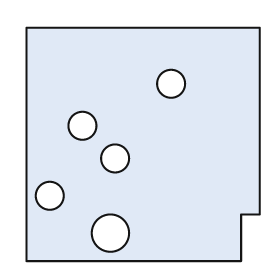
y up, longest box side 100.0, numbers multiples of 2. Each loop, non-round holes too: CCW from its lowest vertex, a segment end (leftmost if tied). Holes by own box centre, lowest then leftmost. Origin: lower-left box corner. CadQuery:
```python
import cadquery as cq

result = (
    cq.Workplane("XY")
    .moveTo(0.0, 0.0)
    .lineTo(92.0, 0.0)
    .lineTo(92.0, 20.0)
    .lineTo(100.0, 20.0)
    .lineTo(100.0, 100.0)
    .lineTo(0.0, 100.0)
    .close()
    .moveTo(36.0, 12.0)
    .circle(8.0)
    .moveTo(10.0, 28.0)
    .circle(6.0)
    .moveTo(38.0, 44.0)
    .circle(6.0)
    .moveTo(24.0, 58.0)
    .circle(6.0)
    .moveTo(62.0, 76.0)
    .circle(6.0)
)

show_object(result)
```